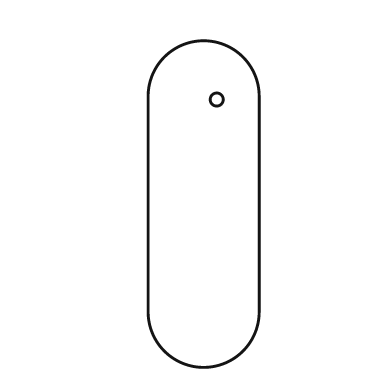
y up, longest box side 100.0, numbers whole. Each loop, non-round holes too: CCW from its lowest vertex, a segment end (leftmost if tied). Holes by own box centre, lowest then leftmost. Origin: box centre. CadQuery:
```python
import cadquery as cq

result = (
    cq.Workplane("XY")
    .moveTo(-17.0, -33.0)
    .threePointArc((0.0, -50.0), (17.0, -33.0))
    .lineTo(17.0, 33.0)
    .threePointArc((0.0, 50.0), (-17.0, 33.0))
    .close()
    .moveTo(4.0, 32.0)
    .circle(2.0)
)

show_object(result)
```